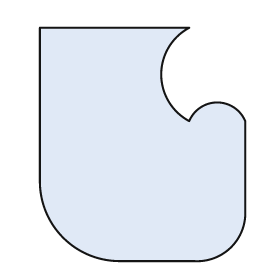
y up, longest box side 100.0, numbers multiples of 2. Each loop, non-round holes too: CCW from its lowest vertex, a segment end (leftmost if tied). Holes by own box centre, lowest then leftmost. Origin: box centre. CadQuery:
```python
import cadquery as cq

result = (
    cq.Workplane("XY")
    .moveTo(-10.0, -50.0)
    .lineTo(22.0, -50.0)
    .threePointArc((38.0, -44.0), (44.0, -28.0))
    .lineTo(44.0, 10.0)
    .threePointArc((32.0, 18.0), (20.0, 10.0))
    .threePointArc((8.0, 30.0), (20.0, 50.0))
    .lineTo(-44.0, 50.0)
    .lineTo(-44.0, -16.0)
    .threePointArc((-34.0, -40.0), (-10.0, -50.0))
    .close()
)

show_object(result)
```